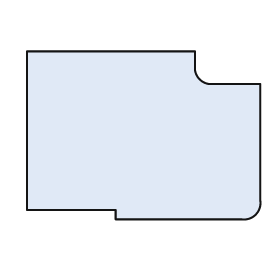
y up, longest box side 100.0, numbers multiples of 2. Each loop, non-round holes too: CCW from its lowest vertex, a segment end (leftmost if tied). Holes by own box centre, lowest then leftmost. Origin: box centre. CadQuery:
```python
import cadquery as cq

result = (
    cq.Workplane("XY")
    .moveTo(-12.0, -36.0)
    .lineTo(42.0, -36.0)
    .threePointArc((48.0, -34.0), (50.0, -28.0))
    .lineTo(50.0, 22.0)
    .lineTo(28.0, 22.0)
    .threePointArc((24.0, 24.0), (22.0, 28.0))
    .lineTo(22.0, 36.0)
    .lineTo(-50.0, 36.0)
    .lineTo(-50.0, -32.0)
    .lineTo(-12.0, -32.0)
    .close()
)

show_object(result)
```